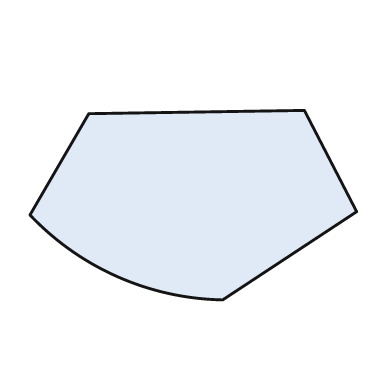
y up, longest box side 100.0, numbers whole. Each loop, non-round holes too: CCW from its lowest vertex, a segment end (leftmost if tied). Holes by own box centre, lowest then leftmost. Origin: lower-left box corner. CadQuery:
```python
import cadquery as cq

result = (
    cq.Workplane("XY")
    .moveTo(59.0, 0.0)
    .lineTo(100.0, 27.0)
    .lineTo(84.0, 58.0)
    .lineTo(18.0, 57.0)
    .lineTo(0.0, 26.0)
    .threePointArc((27.0, 7.0), (59.0, 0.0))
    .close()
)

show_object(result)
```